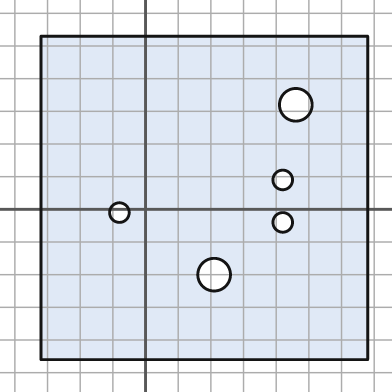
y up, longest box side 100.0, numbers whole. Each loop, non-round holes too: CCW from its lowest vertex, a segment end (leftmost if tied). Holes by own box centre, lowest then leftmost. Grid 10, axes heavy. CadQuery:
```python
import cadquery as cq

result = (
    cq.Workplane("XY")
    .moveTo(-32.0, -46.0)
    .lineTo(68.0, -46.0)
    .lineTo(68.0, 53.0)
    .lineTo(-32.0, 53.0)
    .close()
    .moveTo(21.0, -20.0)
    .circle(5.0)
    .moveTo(42.0, -4.0)
    .circle(3.0)
    .moveTo(-8.0, -1.0)
    .circle(3.0)
    .moveTo(42.0, 9.0)
    .circle(3.0)
    .moveTo(46.0, 32.0)
    .circle(5.0)
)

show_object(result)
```